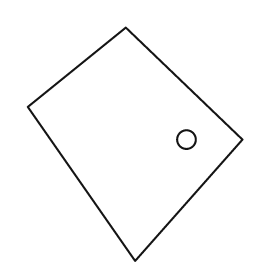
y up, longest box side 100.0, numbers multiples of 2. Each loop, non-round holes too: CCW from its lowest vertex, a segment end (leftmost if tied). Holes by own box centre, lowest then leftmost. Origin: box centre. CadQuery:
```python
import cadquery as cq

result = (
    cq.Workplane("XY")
    .moveTo(0.0, -50.0)
    .lineTo(46.0, 2.0)
    .lineTo(-4.0, 50.0)
    .lineTo(-46.0, 16.0)
    .close()
    .moveTo(22.0, 2.0)
    .circle(4.0)
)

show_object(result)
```